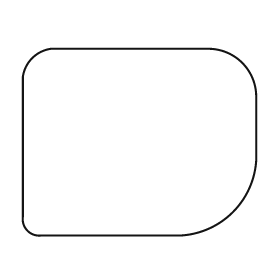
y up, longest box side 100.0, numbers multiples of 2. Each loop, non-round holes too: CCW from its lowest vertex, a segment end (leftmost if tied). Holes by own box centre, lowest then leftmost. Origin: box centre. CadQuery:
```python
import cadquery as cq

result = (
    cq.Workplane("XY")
    .moveTo(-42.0, -40.0)
    .lineTo(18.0, -40.0)
    .threePointArc((40.0, -30.0), (50.0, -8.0))
    .lineTo(50.0, 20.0)
    .threePointArc((44.0, 34.0), (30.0, 40.0))
    .lineTo(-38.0, 40.0)
    .threePointArc((-46.0, 36.0), (-50.0, 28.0))
    .lineTo(-50.0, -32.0)
    .threePointArc((-48.0, -38.0), (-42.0, -40.0))
    .close()
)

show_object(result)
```